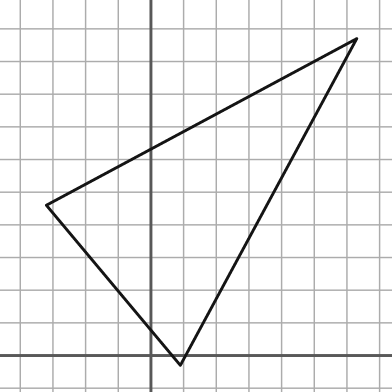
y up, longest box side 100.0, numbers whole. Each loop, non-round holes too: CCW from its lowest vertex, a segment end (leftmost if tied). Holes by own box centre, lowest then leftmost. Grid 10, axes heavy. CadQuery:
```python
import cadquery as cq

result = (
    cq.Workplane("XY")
    .moveTo(9.0, -3.0)
    .lineTo(63.0, 97.0)
    .lineTo(-32.0, 46.0)
    .close()
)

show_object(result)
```